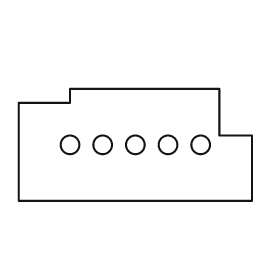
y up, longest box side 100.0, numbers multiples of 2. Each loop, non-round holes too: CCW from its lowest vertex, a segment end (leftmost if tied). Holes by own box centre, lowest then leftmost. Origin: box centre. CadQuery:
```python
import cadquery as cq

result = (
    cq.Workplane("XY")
    .moveTo(-50.0, -24.0)
    .lineTo(50.0, -24.0)
    .lineTo(50.0, 4.0)
    .lineTo(36.0, 4.0)
    .lineTo(36.0, 24.0)
    .lineTo(-28.0, 24.0)
    .lineTo(-28.0, 18.0)
    .lineTo(-50.0, 18.0)
    .close()
    .moveTo(-28.0, 0.0)
    .circle(4.0)
    .moveTo(-14.0, 0.0)
    .circle(4.0)
    .moveTo(0.0, 0.0)
    .circle(4.0)
    .moveTo(14.0, 0.0)
    .circle(4.0)
    .moveTo(28.0, 0.0)
    .circle(4.0)
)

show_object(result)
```